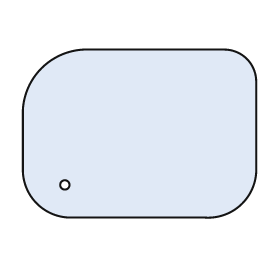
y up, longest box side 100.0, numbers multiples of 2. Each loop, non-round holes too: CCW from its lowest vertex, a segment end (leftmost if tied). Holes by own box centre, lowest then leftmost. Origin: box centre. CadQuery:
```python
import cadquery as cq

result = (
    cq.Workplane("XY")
    .moveTo(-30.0, -36.0)
    .lineTo(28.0, -36.0)
    .threePointArc((44.0, -30.0), (50.0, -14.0))
    .lineTo(50.0, 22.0)
    .threePointArc((46.0, 32.0), (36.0, 36.0))
    .lineTo(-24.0, 36.0)
    .threePointArc((-42.0, 28.0), (-50.0, 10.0))
    .lineTo(-50.0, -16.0)
    .threePointArc((-44.0, -30.0), (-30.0, -36.0))
    .close()
    .moveTo(-32.0, -22.0)
    .circle(2.0)
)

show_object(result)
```